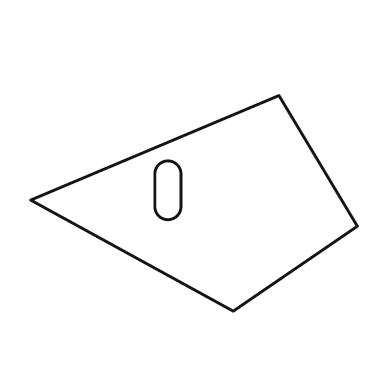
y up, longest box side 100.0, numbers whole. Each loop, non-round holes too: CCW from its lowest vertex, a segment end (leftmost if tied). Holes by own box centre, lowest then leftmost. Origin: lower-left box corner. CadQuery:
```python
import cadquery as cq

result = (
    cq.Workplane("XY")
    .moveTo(62.0, 0.0)
    .lineTo(100.0, 26.0)
    .lineTo(76.0, 66.0)
    .lineTo(0.0, 34.0)
    .close()
    .moveTo(38.0, 32.0)
    .threePointArc((42.0, 28.0), (46.0, 32.0))
    .lineTo(46.0, 42.0)
    .threePointArc((42.0, 46.0), (38.0, 42.0))
    .close()
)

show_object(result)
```